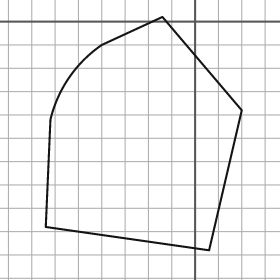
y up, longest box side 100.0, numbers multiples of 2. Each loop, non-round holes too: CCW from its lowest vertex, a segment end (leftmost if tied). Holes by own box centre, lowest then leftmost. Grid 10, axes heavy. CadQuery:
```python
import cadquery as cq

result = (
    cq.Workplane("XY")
    .moveTo(6.0, -98.0)
    .lineTo(20.0, -38.0)
    .lineTo(-14.0, 2.0)
    .lineTo(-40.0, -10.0)
    .threePointArc((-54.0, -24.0), (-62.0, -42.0))
    .lineTo(-64.0, -88.0)
    .close()
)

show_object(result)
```